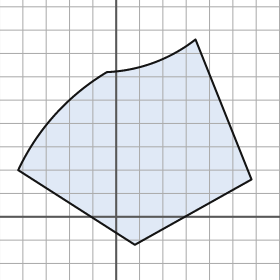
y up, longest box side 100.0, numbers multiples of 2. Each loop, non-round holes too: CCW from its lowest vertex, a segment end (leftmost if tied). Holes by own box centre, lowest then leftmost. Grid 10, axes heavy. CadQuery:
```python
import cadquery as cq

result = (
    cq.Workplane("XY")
    .moveTo(8.0, -12.0)
    .lineTo(58.0, 16.0)
    .lineTo(34.0, 76.0)
    .threePointArc((16.0, 66.0), (-4.0, 62.0))
    .threePointArc((-26.0, 44.0), (-42.0, 20.0))
    .close()
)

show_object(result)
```